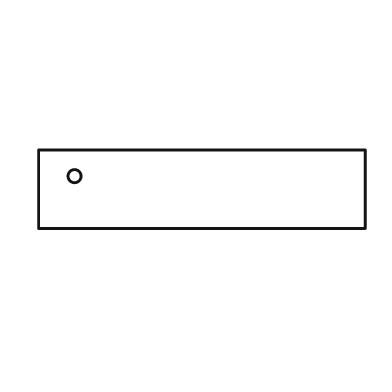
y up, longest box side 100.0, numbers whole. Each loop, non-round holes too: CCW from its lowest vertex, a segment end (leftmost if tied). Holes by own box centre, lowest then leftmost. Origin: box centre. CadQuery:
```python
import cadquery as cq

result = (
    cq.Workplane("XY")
    .moveTo(-50.0, -12.0)
    .lineTo(50.0, -12.0)
    .lineTo(50.0, 12.0)
    .lineTo(-50.0, 12.0)
    .close()
    .moveTo(-39.0, 4.0)
    .circle(2.0)
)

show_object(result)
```